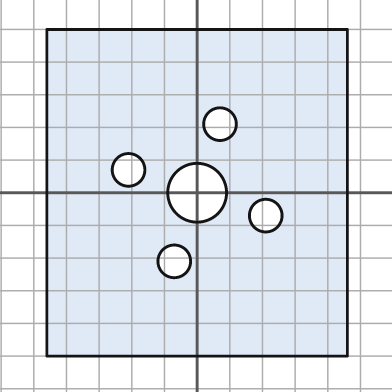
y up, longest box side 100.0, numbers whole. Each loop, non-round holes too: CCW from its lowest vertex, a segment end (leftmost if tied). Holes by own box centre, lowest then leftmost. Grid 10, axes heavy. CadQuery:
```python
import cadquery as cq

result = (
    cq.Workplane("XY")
    .moveTo(-46.0, -50.0)
    .lineTo(46.0, -50.0)
    .lineTo(46.0, 50.0)
    .lineTo(-46.0, 50.0)
    .close()
    .moveTo(-7.0, -21.0)
    .circle(5.0)
    .moveTo(21.0, -7.0)
    .circle(5.0)
    .moveTo(0.0, 0.0)
    .circle(9.0)
    .moveTo(-21.0, 7.0)
    .circle(5.0)
    .moveTo(7.0, 21.0)
    .circle(5.0)
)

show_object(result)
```